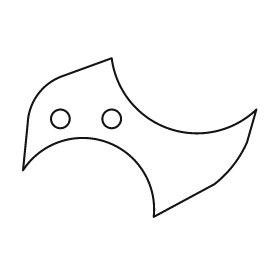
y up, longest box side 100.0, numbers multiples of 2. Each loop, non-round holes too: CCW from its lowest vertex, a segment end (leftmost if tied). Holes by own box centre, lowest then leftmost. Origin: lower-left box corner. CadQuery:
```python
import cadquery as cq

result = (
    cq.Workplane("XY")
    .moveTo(56.0, 0.0)
    .lineTo(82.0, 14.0)
    .threePointArc((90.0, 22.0), (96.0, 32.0))
    .lineTo(100.0, 46.0)
    .threePointArc((62.0, 38.0), (38.0, 68.0))
    .lineTo(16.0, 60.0)
    .threePointArc((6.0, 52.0), (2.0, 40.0))
    .lineTo(0.0, 20.0)
    .threePointArc((36.0, 32.0), (56.0, 0.0))
    .close()
    .moveTo(16.0, 42.0)
    .circle(4.0)
    .moveTo(38.0, 42.0)
    .circle(4.0)
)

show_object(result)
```